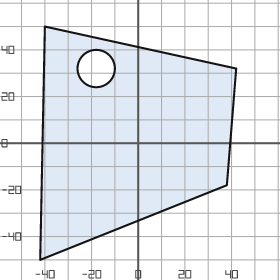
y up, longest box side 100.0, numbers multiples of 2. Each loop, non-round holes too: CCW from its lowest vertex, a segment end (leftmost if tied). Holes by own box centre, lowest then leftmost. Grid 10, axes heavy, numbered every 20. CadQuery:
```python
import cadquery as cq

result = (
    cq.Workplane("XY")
    .moveTo(-42.0, -50.0)
    .lineTo(38.0, -18.0)
    .lineTo(42.0, 32.0)
    .lineTo(-40.0, 50.0)
    .close()
    .moveTo(-18.0, 32.0)
    .circle(8.0)
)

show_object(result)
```